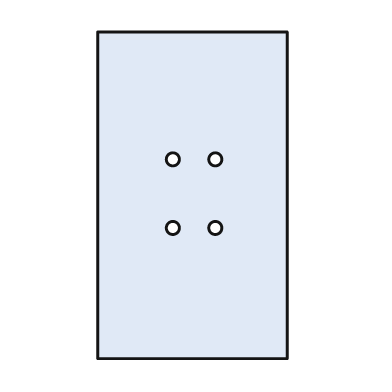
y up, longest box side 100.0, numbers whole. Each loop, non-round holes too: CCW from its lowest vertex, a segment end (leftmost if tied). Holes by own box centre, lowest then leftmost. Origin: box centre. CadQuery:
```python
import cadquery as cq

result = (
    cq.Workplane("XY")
    .moveTo(-29.0, -50.0)
    .lineTo(29.0, -50.0)
    .lineTo(29.0, 50.0)
    .lineTo(-29.0, 50.0)
    .close()
    .moveTo(-6.0, -10.0)
    .circle(2.0)
    .moveTo(7.0, -10.0)
    .circle(2.0)
    .moveTo(-6.0, 11.0)
    .circle(2.0)
    .moveTo(7.0, 11.0)
    .circle(2.0)
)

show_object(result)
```